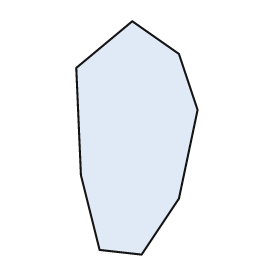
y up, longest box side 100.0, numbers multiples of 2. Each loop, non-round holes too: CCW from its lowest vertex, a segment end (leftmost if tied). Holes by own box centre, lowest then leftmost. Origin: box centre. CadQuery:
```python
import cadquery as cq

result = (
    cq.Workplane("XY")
    .moveTo(2.0, -50.0)
    .lineTo(18.0, -26.0)
    .lineTo(26.0, 12.0)
    .lineTo(18.0, 36.0)
    .lineTo(-2.0, 50.0)
    .lineTo(-26.0, 30.0)
    .lineTo(-24.0, -16.0)
    .lineTo(-16.0, -48.0)
    .close()
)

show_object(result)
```